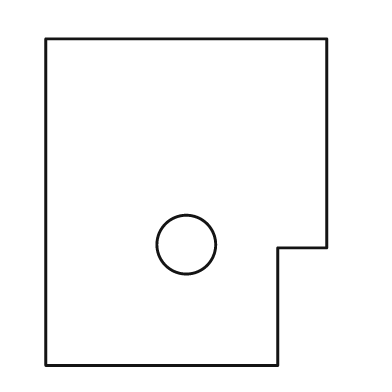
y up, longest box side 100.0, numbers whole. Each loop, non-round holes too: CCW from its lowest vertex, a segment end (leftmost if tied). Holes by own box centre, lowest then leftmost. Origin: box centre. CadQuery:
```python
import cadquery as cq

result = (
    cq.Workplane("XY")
    .moveTo(-43.0, -50.0)
    .lineTo(28.0, -50.0)
    .lineTo(28.0, -14.0)
    .lineTo(43.0, -14.0)
    .lineTo(43.0, 50.0)
    .lineTo(-43.0, 50.0)
    .close()
    .moveTo(0.0, -13.0)
    .circle(9.0)
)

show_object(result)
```